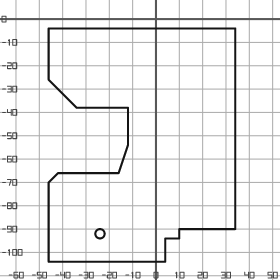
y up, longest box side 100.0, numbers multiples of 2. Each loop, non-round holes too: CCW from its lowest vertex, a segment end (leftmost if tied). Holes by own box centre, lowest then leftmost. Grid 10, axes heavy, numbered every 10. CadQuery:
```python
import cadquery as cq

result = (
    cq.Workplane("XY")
    .moveTo(-46.0, -104.0)
    .lineTo(4.0, -104.0)
    .lineTo(4.0, -94.0)
    .lineTo(10.0, -94.0)
    .lineTo(10.0, -90.0)
    .lineTo(34.0, -90.0)
    .lineTo(34.0, -4.0)
    .lineTo(-46.0, -4.0)
    .lineTo(-46.0, -26.0)
    .lineTo(-34.0, -38.0)
    .lineTo(-12.0, -38.0)
    .lineTo(-12.0, -54.0)
    .lineTo(-16.0, -66.0)
    .lineTo(-42.0, -66.0)
    .lineTo(-46.0, -70.0)
    .close()
    .moveTo(-24.0, -92.0)
    .circle(2.0)
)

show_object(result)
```